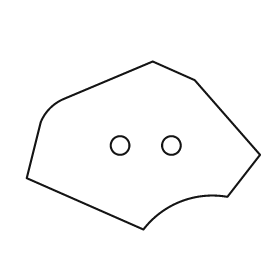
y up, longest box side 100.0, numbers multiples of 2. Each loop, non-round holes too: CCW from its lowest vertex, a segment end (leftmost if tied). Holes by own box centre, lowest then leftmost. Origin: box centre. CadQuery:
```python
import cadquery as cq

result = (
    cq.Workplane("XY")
    .moveTo(0.0, -36.0)
    .threePointArc((16.0, -24.0), (36.0, -22.0))
    .lineTo(50.0, -4.0)
    .lineTo(22.0, 28.0)
    .lineTo(4.0, 36.0)
    .lineTo(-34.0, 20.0)
    .threePointArc((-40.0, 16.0), (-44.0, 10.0))
    .lineTo(-50.0, -14.0)
    .close()
    .moveTo(-10.0, 0.0)
    .circle(4.0)
    .moveTo(12.0, 0.0)
    .circle(4.0)
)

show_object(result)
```